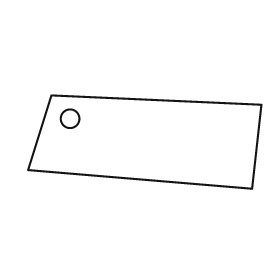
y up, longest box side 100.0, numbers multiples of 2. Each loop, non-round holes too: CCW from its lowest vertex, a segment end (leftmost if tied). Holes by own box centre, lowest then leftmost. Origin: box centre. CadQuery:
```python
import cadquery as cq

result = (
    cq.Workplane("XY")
    .moveTo(46.0, -20.0)
    .lineTo(50.0, 16.0)
    .lineTo(-40.0, 20.0)
    .lineTo(-50.0, -12.0)
    .close()
    .moveTo(-32.0, 10.0)
    .circle(4.0)
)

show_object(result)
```